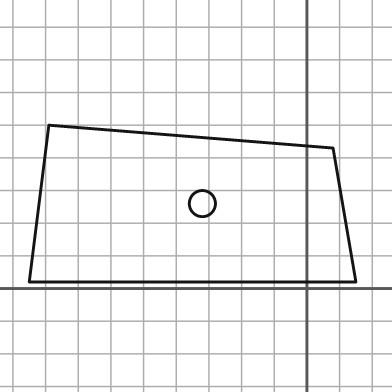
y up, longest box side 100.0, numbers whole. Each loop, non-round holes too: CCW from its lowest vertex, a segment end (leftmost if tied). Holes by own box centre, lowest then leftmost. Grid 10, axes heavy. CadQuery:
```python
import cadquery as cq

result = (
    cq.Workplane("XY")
    .moveTo(-85.0, 2.0)
    .lineTo(15.0, 2.0)
    .lineTo(8.0, 43.0)
    .lineTo(-79.0, 50.0)
    .close()
    .moveTo(-32.0, 26.0)
    .circle(4.0)
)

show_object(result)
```